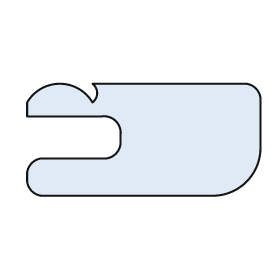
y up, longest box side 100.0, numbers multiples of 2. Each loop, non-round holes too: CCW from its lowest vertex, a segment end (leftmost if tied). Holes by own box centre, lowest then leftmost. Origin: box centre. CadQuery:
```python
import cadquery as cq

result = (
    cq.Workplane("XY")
    .moveTo(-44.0, -24.0)
    .lineTo(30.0, -24.0)
    .threePointArc((44.0, -18.0), (50.0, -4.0))
    .lineTo(50.0, 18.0)
    .threePointArc((48.0, 22.0), (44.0, 24.0))
    .lineTo(-22.0, 24.0)
    .threePointArc((-20.0, 20.0), (-22.0, 16.0))
    .threePointArc((-36.0, 24.0), (-50.0, 16.0))
    .lineTo(-50.0, 10.0)
    .lineTo(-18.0, 10.0)
    .threePointArc((-12.0, 8.0), (-10.0, 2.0))
    .lineTo(-10.0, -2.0)
    .threePointArc((-12.0, -6.0), (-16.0, -8.0))
    .lineTo(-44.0, -8.0)
    .threePointArc((-48.0, -10.0), (-50.0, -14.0))
    .lineTo(-50.0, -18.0)
    .threePointArc((-48.0, -22.0), (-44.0, -24.0))
    .close()
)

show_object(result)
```